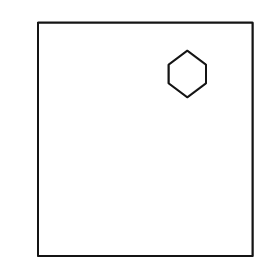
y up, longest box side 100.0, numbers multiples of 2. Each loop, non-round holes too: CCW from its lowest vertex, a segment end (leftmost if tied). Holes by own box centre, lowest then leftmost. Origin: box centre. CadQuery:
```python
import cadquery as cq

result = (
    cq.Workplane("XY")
    .moveTo(-46.0, -50.0)
    .lineTo(46.0, -50.0)
    .lineTo(46.0, 50.0)
    .lineTo(-46.0, 50.0)
    .close()
    .moveTo(18.0, 18.0)
    .lineTo(26.0, 24.0)
    .lineTo(26.0, 32.0)
    .lineTo(18.0, 38.0)
    .lineTo(10.0, 32.0)
    .lineTo(10.0, 24.0)
    .close()
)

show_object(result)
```